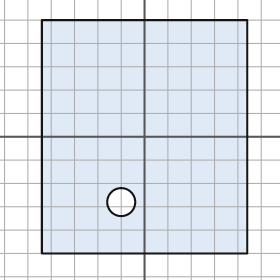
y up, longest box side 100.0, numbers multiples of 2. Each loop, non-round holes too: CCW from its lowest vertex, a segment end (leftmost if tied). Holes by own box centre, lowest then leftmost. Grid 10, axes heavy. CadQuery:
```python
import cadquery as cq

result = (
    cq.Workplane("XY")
    .moveTo(-44.0, -50.0)
    .lineTo(44.0, -50.0)
    .lineTo(44.0, 50.0)
    .lineTo(-44.0, 50.0)
    .close()
    .moveTo(-10.0, -28.0)
    .circle(6.0)
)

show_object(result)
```